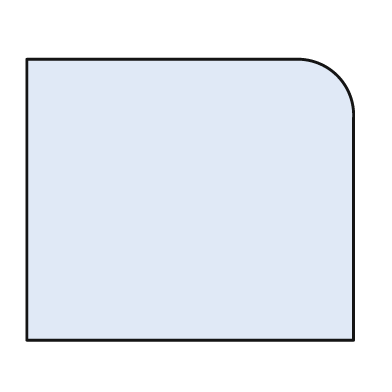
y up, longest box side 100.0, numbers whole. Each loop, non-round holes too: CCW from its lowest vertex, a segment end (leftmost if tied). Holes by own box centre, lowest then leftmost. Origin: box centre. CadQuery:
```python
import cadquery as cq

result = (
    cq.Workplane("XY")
    .moveTo(-50.0, -43.0)
    .lineTo(50.0, -43.0)
    .lineTo(50.0, 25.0)
    .threePointArc((45.0, 38.0), (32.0, 43.0))
    .lineTo(-50.0, 43.0)
    .close()
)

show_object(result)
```